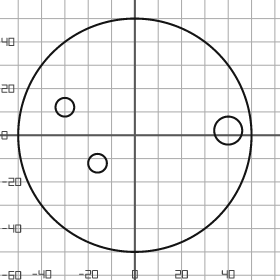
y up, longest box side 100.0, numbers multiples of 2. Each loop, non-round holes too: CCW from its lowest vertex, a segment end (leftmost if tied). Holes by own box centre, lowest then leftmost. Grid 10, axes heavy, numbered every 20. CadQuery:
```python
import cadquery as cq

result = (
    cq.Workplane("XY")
    .moveTo(0.0, 0.0)
    .circle(50.0)
    .moveTo(-16.0, -12.0)
    .circle(4.0)
    .moveTo(40.0, 2.0)
    .circle(6.0)
    .moveTo(-30.0, 12.0)
    .circle(4.0)
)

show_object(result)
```